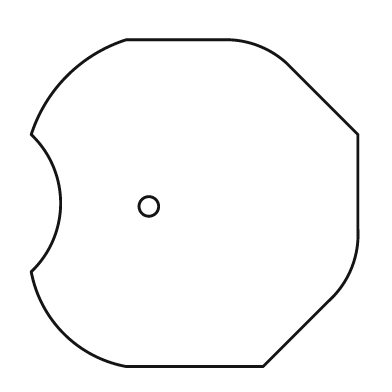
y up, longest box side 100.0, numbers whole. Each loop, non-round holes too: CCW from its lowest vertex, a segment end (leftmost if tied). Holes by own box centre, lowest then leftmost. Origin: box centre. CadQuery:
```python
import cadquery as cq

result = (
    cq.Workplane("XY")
    .moveTo(-21.0, -50.0)
    .lineTo(21.0, -50.0)
    .lineTo(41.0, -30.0)
    .threePointArc((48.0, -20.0), (50.0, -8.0))
    .lineTo(50.0, 21.0)
    .lineTo(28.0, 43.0)
    .threePointArc((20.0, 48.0), (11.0, 50.0))
    .lineTo(-21.0, 50.0)
    .threePointArc((-39.0, 39.0), (-50.0, 21.0))
    .threePointArc((-41.0, 0.0), (-50.0, -21.0))
    .threePointArc((-40.0, -40.0), (-21.0, -50.0))
    .close()
    .moveTo(-14.0, -1.0)
    .circle(3.0)
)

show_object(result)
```